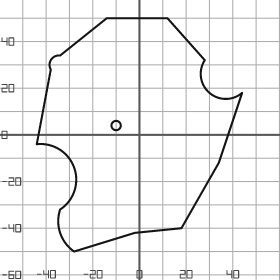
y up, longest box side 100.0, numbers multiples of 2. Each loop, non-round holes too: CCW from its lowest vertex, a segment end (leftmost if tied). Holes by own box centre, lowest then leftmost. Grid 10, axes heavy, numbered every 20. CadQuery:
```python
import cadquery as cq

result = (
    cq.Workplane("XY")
    .moveTo(-28.0, -50.0)
    .lineTo(-2.0, -42.0)
    .lineTo(18.0, -40.0)
    .lineTo(34.0, -12.0)
    .lineTo(44.0, 18.0)
    .threePointArc((30.0, 18.0), (28.0, 32.0))
    .lineTo(12.0, 50.0)
    .lineTo(-14.0, 50.0)
    .lineTo(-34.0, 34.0)
    .threePointArc((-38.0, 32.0), (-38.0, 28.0))
    .lineTo(-44.0, -4.0)
    .threePointArc((-28.0, -14.0), (-34.0, -32.0))
    .threePointArc((-34.0, -42.0), (-28.0, -50.0))
    .close()
    .moveTo(-10.0, 4.0)
    .circle(2.0)
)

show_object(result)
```